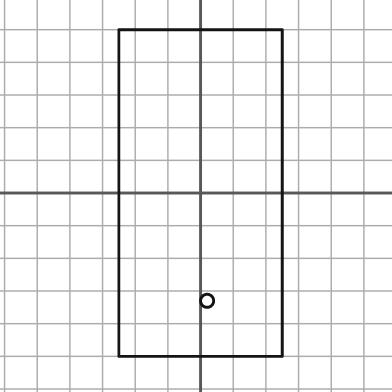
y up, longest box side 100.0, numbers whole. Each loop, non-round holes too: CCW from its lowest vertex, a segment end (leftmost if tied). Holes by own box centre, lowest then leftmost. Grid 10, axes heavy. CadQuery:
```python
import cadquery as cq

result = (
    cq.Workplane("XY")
    .moveTo(-25.0, -50.0)
    .lineTo(25.0, -50.0)
    .lineTo(25.0, 50.0)
    .lineTo(-25.0, 50.0)
    .close()
    .moveTo(2.0, -33.0)
    .circle(2.0)
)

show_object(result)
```